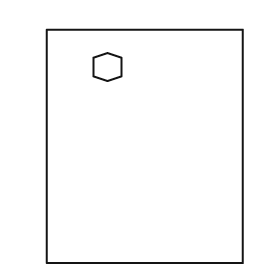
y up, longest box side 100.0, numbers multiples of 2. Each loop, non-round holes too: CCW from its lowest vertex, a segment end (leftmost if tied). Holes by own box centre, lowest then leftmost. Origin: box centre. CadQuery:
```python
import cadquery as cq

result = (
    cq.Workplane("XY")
    .moveTo(-42.0, -50.0)
    .lineTo(42.0, -50.0)
    .lineTo(42.0, 50.0)
    .lineTo(-42.0, 50.0)
    .close()
    .moveTo(-16.0, 28.0)
    .lineTo(-10.0, 30.0)
    .lineTo(-10.0, 38.0)
    .lineTo(-16.0, 40.0)
    .lineTo(-22.0, 38.0)
    .lineTo(-22.0, 30.0)
    .close()
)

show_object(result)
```